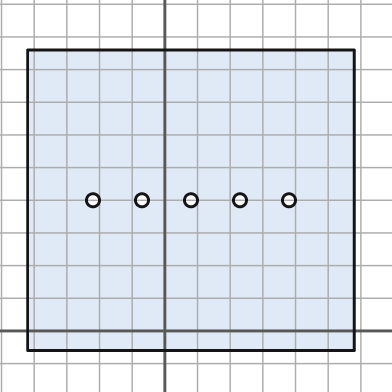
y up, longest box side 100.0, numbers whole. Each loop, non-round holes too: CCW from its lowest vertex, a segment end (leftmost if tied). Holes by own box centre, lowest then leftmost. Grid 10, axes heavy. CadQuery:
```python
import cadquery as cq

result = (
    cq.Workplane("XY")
    .moveTo(-42.0, -6.0)
    .lineTo(58.0, -6.0)
    .lineTo(58.0, 86.0)
    .lineTo(-42.0, 86.0)
    .close()
    .moveTo(-22.0, 40.0)
    .circle(2.0)
    .moveTo(-7.0, 40.0)
    .circle(2.0)
    .moveTo(8.0, 40.0)
    .circle(2.0)
    .moveTo(23.0, 40.0)
    .circle(2.0)
    .moveTo(38.0, 40.0)
    .circle(2.0)
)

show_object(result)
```